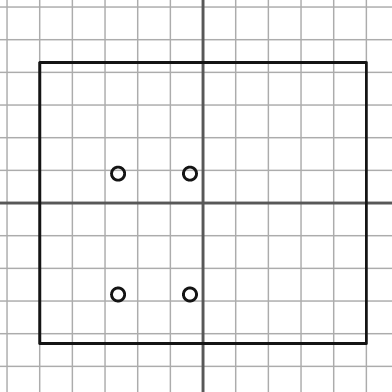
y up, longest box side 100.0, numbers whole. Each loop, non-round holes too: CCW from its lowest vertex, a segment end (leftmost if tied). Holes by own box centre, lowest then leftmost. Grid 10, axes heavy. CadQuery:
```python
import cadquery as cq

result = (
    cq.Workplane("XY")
    .moveTo(-50.0, -43.0)
    .lineTo(50.0, -43.0)
    .lineTo(50.0, 43.0)
    .lineTo(-50.0, 43.0)
    .close()
    .moveTo(-26.0, -28.0)
    .circle(2.0)
    .moveTo(-4.0, -28.0)
    .circle(2.0)
    .moveTo(-26.0, 9.0)
    .circle(2.0)
    .moveTo(-4.0, 9.0)
    .circle(2.0)
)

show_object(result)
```